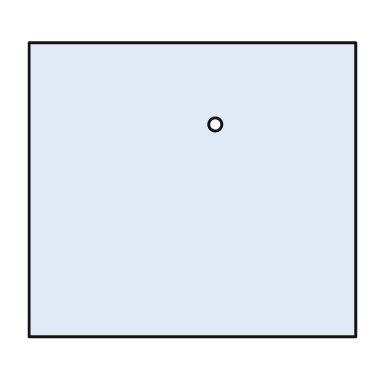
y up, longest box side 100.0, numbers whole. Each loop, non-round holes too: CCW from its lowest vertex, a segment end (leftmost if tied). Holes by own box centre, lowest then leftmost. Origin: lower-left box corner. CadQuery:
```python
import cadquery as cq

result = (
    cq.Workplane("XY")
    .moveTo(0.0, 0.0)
    .lineTo(100.0, 0.0)
    .lineTo(100.0, 90.0)
    .lineTo(0.0, 90.0)
    .close()
    .moveTo(57.0, 65.0)
    .circle(2.0)
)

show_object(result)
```